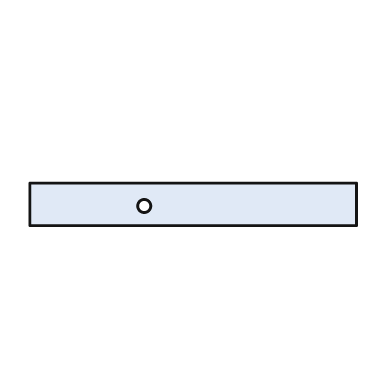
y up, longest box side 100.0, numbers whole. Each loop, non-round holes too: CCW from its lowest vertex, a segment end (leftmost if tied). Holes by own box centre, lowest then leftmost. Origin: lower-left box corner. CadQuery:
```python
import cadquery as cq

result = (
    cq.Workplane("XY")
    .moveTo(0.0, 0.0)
    .lineTo(100.0, 0.0)
    .lineTo(100.0, 13.0)
    .lineTo(0.0, 13.0)
    .close()
    .moveTo(35.0, 6.0)
    .circle(2.0)
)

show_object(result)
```